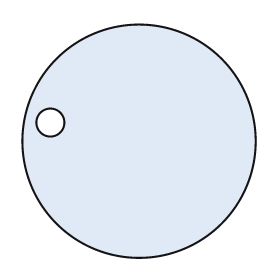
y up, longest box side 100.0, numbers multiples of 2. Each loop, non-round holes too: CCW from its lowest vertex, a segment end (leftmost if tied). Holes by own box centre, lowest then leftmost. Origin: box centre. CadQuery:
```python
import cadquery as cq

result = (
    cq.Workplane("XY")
    .moveTo(0.0, 0.0)
    .circle(50.0)
    .moveTo(-38.0, 8.0)
    .circle(6.0)
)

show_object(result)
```